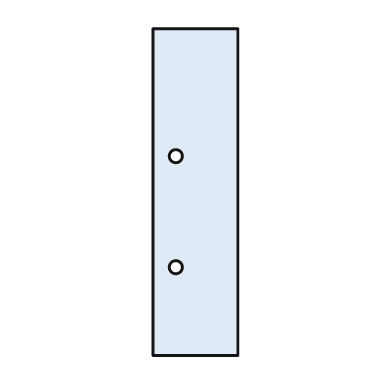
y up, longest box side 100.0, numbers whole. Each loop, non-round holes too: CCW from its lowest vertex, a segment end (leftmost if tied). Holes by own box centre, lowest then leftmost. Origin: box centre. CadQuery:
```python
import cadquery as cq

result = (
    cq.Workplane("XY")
    .moveTo(-13.0, -50.0)
    .lineTo(13.0, -50.0)
    .lineTo(13.0, 50.0)
    .lineTo(-13.0, 50.0)
    .close()
    .moveTo(-6.0, -23.0)
    .circle(2.0)
    .moveTo(-6.0, 11.0)
    .circle(2.0)
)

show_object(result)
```